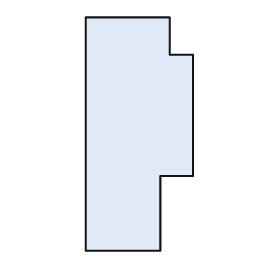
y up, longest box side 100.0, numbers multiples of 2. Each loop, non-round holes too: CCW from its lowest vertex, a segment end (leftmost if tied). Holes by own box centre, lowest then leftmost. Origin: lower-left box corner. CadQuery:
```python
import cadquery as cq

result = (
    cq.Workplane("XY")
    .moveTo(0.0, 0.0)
    .lineTo(32.0, 0.0)
    .lineTo(32.0, 32.0)
    .lineTo(46.0, 32.0)
    .lineTo(46.0, 84.0)
    .lineTo(36.0, 84.0)
    .lineTo(36.0, 100.0)
    .lineTo(0.0, 100.0)
    .close()
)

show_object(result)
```